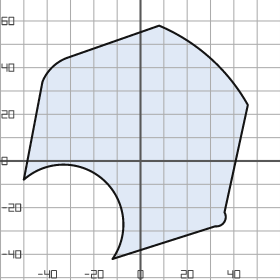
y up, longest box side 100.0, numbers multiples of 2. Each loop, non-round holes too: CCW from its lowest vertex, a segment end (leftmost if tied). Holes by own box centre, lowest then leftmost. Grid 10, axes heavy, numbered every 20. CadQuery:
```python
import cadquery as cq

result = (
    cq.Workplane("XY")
    .moveTo(-12.0, -42.0)
    .lineTo(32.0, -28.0)
    .threePointArc((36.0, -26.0), (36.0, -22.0))
    .lineTo(46.0, 24.0)
    .threePointArc((30.0, 44.0), (8.0, 58.0))
    .lineTo(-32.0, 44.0)
    .threePointArc((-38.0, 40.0), (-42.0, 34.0))
    .lineTo(-50.0, -8.0)
    .threePointArc((-16.0, -8.0), (-12.0, -42.0))
    .close()
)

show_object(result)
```